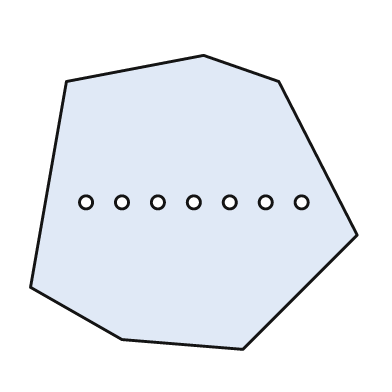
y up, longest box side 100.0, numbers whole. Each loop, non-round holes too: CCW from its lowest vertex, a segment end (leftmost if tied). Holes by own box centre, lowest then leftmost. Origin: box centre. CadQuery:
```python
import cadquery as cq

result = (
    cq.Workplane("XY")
    .moveTo(15.0, -45.0)
    .lineTo(50.0, -10.0)
    .lineTo(26.0, 37.0)
    .lineTo(3.0, 45.0)
    .lineTo(-39.0, 37.0)
    .lineTo(-50.0, -26.0)
    .lineTo(-22.0, -42.0)
    .close()
    .moveTo(-33.0, 0.0)
    .circle(2.0)
    .moveTo(-22.0, 0.0)
    .circle(2.0)
    .moveTo(-11.0, 0.0)
    .circle(2.0)
    .moveTo(0.0, 0.0)
    .circle(2.0)
    .moveTo(11.0, 0.0)
    .circle(2.0)
    .moveTo(22.0, 0.0)
    .circle(2.0)
    .moveTo(33.0, 0.0)
    .circle(2.0)
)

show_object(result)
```